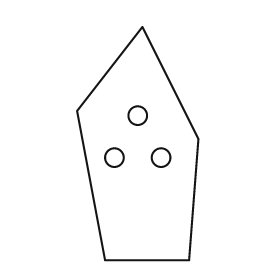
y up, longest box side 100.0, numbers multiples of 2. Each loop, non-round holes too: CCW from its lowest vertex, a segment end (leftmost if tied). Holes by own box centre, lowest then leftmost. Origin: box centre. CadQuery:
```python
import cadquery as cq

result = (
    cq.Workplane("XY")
    .moveTo(-14.0, -50.0)
    .lineTo(22.0, -50.0)
    .lineTo(26.0, 2.0)
    .lineTo(2.0, 50.0)
    .lineTo(-26.0, 14.0)
    .close()
    .moveTo(-10.0, -6.0)
    .circle(4.0)
    .moveTo(10.0, -6.0)
    .circle(4.0)
    .moveTo(0.0, 12.0)
    .circle(4.0)
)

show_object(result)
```